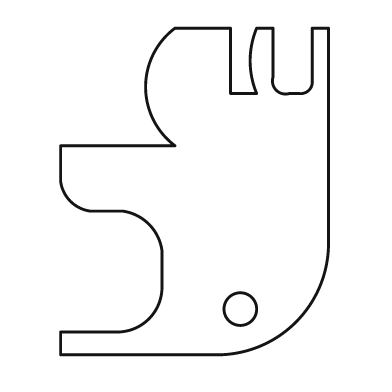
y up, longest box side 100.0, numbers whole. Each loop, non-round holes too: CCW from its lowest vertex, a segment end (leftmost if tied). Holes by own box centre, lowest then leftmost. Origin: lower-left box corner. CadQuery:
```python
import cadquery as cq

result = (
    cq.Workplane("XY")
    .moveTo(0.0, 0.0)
    .lineTo(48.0, 0.0)
    .threePointArc((72.0, 10.0), (82.0, 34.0))
    .lineTo(82.0, 100.0)
    .lineTo(77.0, 100.0)
    .lineTo(77.0, 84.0)
    .threePointArc((76.0, 81.0), (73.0, 80.0))
    .lineTo(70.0, 80.0)
    .threePointArc((66.0, 81.0), (65.0, 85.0))
    .lineTo(65.0, 100.0)
    .lineTo(60.0, 100.0)
    .threePointArc((58.0, 90.0), (60.0, 80.0))
    .lineTo(52.0, 80.0)
    .lineTo(52.0, 100.0)
    .lineTo(35.0, 100.0)
    .threePointArc((26.0, 82.0), (35.0, 64.0))
    .lineTo(0.0, 64.0)
    .lineTo(0.0, 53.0)
    .threePointArc((3.0, 47.0), (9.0, 44.0))
    .lineTo(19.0, 44.0)
    .threePointArc((27.0, 40.0), (31.0, 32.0))
    .lineTo(31.0, 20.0)
    .threePointArc((27.0, 11.0), (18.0, 7.0))
    .lineTo(0.0, 7.0)
    .close()
    .moveTo(55.0, 14.0)
    .circle(5.0)
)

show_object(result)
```